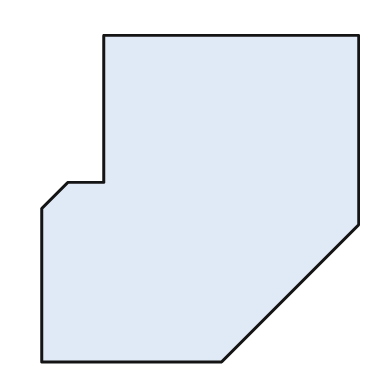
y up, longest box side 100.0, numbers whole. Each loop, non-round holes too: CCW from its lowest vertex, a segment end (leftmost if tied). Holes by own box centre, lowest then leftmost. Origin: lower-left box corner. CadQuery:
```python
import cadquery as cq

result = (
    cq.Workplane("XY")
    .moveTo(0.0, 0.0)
    .lineTo(55.0, 0.0)
    .lineTo(97.0, 42.0)
    .lineTo(97.0, 100.0)
    .lineTo(19.0, 100.0)
    .lineTo(19.0, 55.0)
    .lineTo(8.0, 55.0)
    .lineTo(0.0, 47.0)
    .close()
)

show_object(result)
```